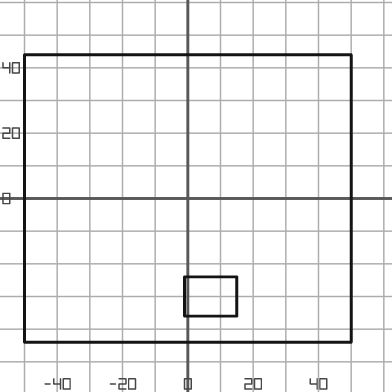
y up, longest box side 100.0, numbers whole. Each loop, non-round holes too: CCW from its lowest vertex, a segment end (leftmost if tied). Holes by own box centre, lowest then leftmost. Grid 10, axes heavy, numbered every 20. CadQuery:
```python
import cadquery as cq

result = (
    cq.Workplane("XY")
    .moveTo(-50.0, -44.0)
    .lineTo(50.0, -44.0)
    .lineTo(50.0, 44.0)
    .lineTo(-50.0, 44.0)
    .close()
    .moveTo(-1.0, -36.0)
    .lineTo(15.0, -36.0)
    .lineTo(15.0, -24.0)
    .lineTo(-1.0, -24.0)
    .close()
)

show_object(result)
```